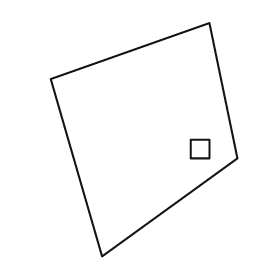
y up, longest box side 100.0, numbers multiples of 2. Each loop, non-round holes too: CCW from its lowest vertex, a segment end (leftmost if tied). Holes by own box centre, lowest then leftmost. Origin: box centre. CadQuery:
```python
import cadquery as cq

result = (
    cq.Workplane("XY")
    .moveTo(-18.0, -50.0)
    .lineTo(40.0, -8.0)
    .lineTo(28.0, 50.0)
    .lineTo(-40.0, 26.0)
    .close()
    .moveTo(20.0, -8.0)
    .lineTo(28.0, -8.0)
    .lineTo(28.0, 0.0)
    .lineTo(20.0, 0.0)
    .close()
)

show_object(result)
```